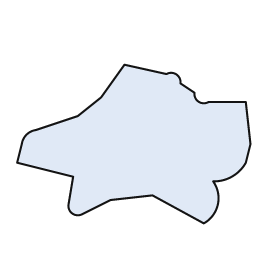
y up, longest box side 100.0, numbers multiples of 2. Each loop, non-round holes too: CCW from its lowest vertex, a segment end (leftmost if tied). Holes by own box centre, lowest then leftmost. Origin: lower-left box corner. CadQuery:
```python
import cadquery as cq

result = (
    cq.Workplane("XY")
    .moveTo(80.0, 0.0)
    .threePointArc((86.0, 8.0), (84.0, 18.0))
    .threePointArc((92.0, 20.0), (98.0, 26.0))
    .lineTo(100.0, 34.0)
    .lineTo(98.0, 52.0)
    .lineTo(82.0, 52.0)
    .threePointArc((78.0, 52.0), (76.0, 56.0))
    .lineTo(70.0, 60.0)
    .threePointArc((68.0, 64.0), (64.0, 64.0))
    .lineTo(46.0, 68.0)
    .lineTo(36.0, 54.0)
    .lineTo(26.0, 46.0)
    .lineTo(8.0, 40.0)
    .threePointArc((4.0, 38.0), (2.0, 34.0))
    .lineTo(0.0, 26.0)
    .lineTo(24.0, 20.0)
    .lineTo(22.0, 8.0)
    .threePointArc((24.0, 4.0), (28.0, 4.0))
    .lineTo(40.0, 10.0)
    .lineTo(58.0, 12.0)
    .close()
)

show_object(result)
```